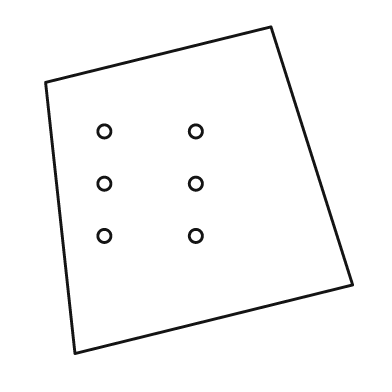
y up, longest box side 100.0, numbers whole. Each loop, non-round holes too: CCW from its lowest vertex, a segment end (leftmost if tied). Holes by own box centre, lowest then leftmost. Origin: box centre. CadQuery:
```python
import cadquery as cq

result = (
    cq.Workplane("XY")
    .moveTo(-38.0, -50.0)
    .lineTo(47.0, -29.0)
    .lineTo(22.0, 50.0)
    .lineTo(-47.0, 33.0)
    .close()
    .moveTo(-29.0, -14.0)
    .circle(2.0)
    .moveTo(-1.0, -14.0)
    .circle(2.0)
    .moveTo(-29.0, 2.0)
    .circle(2.0)
    .moveTo(-1.0, 2.0)
    .circle(2.0)
    .moveTo(-29.0, 18.0)
    .circle(2.0)
    .moveTo(-1.0, 18.0)
    .circle(2.0)
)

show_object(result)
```